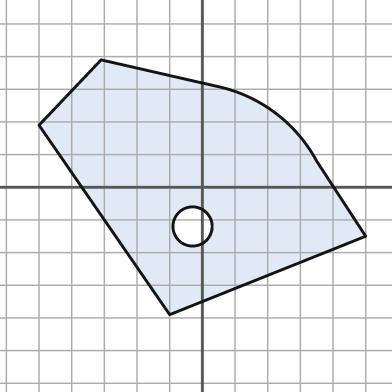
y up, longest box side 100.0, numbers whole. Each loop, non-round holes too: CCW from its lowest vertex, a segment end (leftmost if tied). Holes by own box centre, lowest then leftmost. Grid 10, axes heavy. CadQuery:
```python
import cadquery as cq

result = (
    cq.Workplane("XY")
    .moveTo(-10.0, -39.0)
    .lineTo(50.0, -15.0)
    .lineTo(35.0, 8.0)
    .threePointArc((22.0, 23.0), (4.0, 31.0))
    .lineTo(-31.0, 39.0)
    .lineTo(-50.0, 19.0)
    .close()
    .moveTo(-3.0, -12.0)
    .circle(6.0)
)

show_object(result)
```